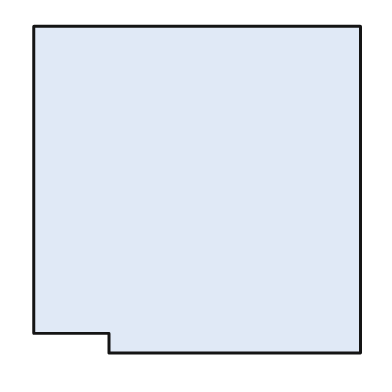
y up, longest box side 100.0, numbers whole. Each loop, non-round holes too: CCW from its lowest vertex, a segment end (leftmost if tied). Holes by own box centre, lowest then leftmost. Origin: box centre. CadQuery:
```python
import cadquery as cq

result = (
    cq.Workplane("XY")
    .moveTo(-27.0, -50.0)
    .lineTo(50.0, -50.0)
    .lineTo(50.0, 50.0)
    .lineTo(-50.0, 50.0)
    .lineTo(-50.0, -44.0)
    .lineTo(-27.0, -44.0)
    .close()
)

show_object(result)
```